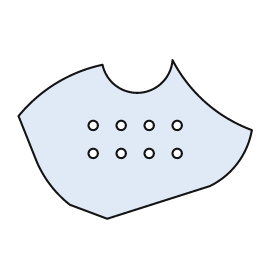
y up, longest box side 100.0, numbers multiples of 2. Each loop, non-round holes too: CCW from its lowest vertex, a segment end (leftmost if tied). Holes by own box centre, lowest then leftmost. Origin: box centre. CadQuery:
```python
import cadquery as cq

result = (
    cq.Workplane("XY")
    .moveTo(-12.0, -34.0)
    .lineTo(32.0, -20.0)
    .threePointArc((44.0, -10.0), (50.0, 4.0))
    .threePointArc((30.0, 16.0), (16.0, 34.0))
    .threePointArc((2.0, 20.0), (-14.0, 32.0))
    .threePointArc((-34.0, 24.0), (-50.0, 10.0))
    .lineTo(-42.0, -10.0)
    .threePointArc((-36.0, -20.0), (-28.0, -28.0))
    .close()
    .moveTo(-18.0, -6.0)
    .circle(2.0)
    .moveTo(-6.0, -6.0)
    .circle(2.0)
    .moveTo(6.0, -6.0)
    .circle(2.0)
    .moveTo(18.0, -6.0)
    .circle(2.0)
    .moveTo(-18.0, 6.0)
    .circle(2.0)
    .moveTo(-6.0, 6.0)
    .circle(2.0)
    .moveTo(6.0, 6.0)
    .circle(2.0)
    .moveTo(18.0, 6.0)
    .circle(2.0)
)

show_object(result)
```